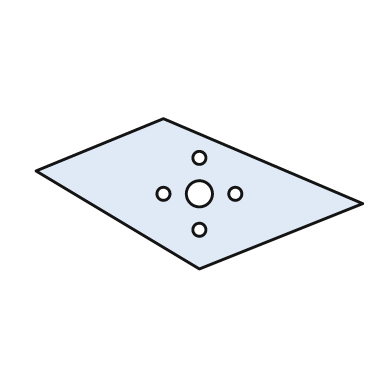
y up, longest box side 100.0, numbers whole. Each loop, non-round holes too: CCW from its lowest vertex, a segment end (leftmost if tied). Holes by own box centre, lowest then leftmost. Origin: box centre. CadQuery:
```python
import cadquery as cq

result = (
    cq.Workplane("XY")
    .moveTo(0.0, -23.0)
    .lineTo(50.0, -3.0)
    .lineTo(-11.0, 23.0)
    .lineTo(-50.0, 7.0)
    .close()
    .moveTo(0.0, -11.0)
    .circle(2.0)
    .moveTo(-11.0, 0.0)
    .circle(2.0)
    .moveTo(0.0, 0.0)
    .circle(4.0)
    .moveTo(11.0, 0.0)
    .circle(2.0)
    .moveTo(0.0, 11.0)
    .circle(2.0)
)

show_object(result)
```